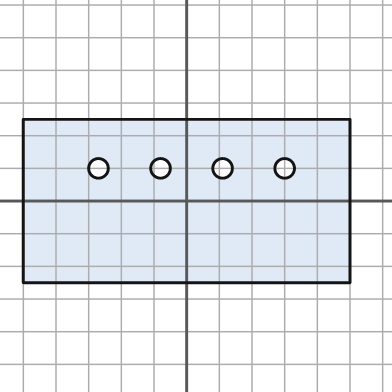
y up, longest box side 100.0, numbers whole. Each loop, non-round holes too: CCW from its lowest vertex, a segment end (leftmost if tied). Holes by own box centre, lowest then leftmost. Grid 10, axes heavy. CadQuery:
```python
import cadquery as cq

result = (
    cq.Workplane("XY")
    .moveTo(-50.0, -25.0)
    .lineTo(50.0, -25.0)
    .lineTo(50.0, 25.0)
    .lineTo(-50.0, 25.0)
    .close()
    .moveTo(-27.0, 10.0)
    .circle(3.0)
    .moveTo(-8.0, 10.0)
    .circle(3.0)
    .moveTo(11.0, 10.0)
    .circle(3.0)
    .moveTo(30.0, 10.0)
    .circle(3.0)
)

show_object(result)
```